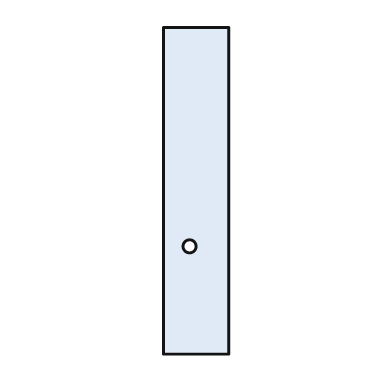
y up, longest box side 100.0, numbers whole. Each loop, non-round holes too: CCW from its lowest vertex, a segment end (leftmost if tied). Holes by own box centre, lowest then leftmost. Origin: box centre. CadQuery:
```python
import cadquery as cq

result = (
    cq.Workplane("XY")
    .moveTo(-10.0, -50.0)
    .lineTo(10.0, -50.0)
    .lineTo(10.0, 50.0)
    .lineTo(-10.0, 50.0)
    .close()
    .moveTo(-2.0, -17.0)
    .circle(2.0)
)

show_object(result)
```